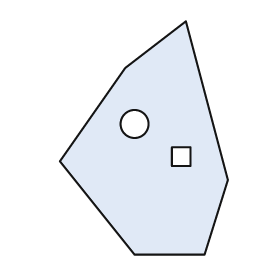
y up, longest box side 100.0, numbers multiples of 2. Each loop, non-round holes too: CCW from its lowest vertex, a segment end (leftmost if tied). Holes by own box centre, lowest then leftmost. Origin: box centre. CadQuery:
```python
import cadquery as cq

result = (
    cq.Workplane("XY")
    .moveTo(-4.0, -50.0)
    .lineTo(26.0, -50.0)
    .lineTo(36.0, -18.0)
    .lineTo(18.0, 50.0)
    .lineTo(-8.0, 30.0)
    .lineTo(-36.0, -10.0)
    .close()
    .moveTo(12.0, -12.0)
    .lineTo(20.0, -12.0)
    .lineTo(20.0, -4.0)
    .lineTo(12.0, -4.0)
    .close()
    .moveTo(-4.0, 6.0)
    .circle(6.0)
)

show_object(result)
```